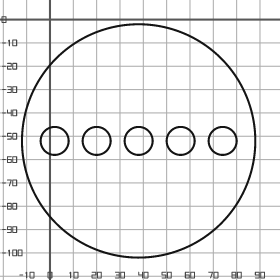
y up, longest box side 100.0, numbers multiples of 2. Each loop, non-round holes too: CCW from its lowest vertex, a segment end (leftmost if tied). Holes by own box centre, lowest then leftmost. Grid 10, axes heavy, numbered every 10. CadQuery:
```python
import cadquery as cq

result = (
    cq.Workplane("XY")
    .moveTo(38.0, -52.0)
    .circle(50.0)
    .moveTo(2.0, -52.0)
    .circle(6.0)
    .moveTo(20.0, -52.0)
    .circle(6.0)
    .moveTo(38.0, -52.0)
    .circle(6.0)
    .moveTo(56.0, -52.0)
    .circle(6.0)
    .moveTo(74.0, -52.0)
    .circle(6.0)
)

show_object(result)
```